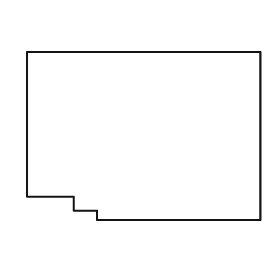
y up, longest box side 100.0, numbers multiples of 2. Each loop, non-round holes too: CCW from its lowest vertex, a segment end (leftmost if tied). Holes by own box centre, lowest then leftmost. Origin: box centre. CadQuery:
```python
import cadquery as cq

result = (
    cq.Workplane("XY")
    .moveTo(-20.0, -36.0)
    .lineTo(50.0, -36.0)
    .lineTo(50.0, 36.0)
    .lineTo(-50.0, 36.0)
    .lineTo(-50.0, -26.0)
    .lineTo(-30.0, -26.0)
    .lineTo(-30.0, -32.0)
    .lineTo(-20.0, -32.0)
    .close()
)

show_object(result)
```